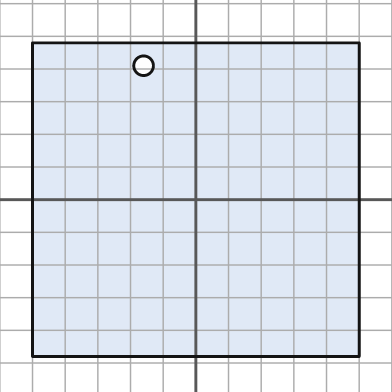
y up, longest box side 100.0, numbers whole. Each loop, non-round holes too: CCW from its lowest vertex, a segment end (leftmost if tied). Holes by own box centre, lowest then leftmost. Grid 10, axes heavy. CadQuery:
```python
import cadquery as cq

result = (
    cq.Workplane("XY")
    .moveTo(-50.0, -48.0)
    .lineTo(50.0, -48.0)
    .lineTo(50.0, 48.0)
    .lineTo(-50.0, 48.0)
    .close()
    .moveTo(-16.0, 41.0)
    .circle(3.0)
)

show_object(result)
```